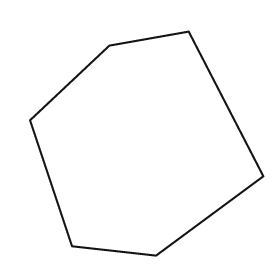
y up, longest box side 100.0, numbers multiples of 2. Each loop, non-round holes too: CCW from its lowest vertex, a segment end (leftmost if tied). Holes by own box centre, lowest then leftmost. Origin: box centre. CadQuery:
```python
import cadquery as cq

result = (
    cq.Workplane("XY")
    .moveTo(4.0, -48.0)
    .lineTo(50.0, -14.0)
    .lineTo(18.0, 48.0)
    .lineTo(-16.0, 42.0)
    .lineTo(-50.0, 10.0)
    .lineTo(-32.0, -44.0)
    .close()
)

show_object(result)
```